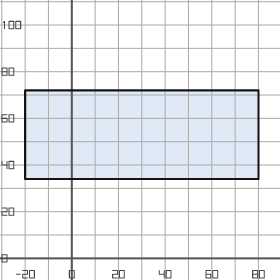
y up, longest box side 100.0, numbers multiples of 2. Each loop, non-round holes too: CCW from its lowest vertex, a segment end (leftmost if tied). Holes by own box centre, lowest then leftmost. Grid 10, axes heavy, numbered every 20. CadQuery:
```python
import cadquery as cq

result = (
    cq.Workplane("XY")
    .moveTo(-20.0, 34.0)
    .lineTo(80.0, 34.0)
    .lineTo(80.0, 72.0)
    .lineTo(-20.0, 72.0)
    .close()
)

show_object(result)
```